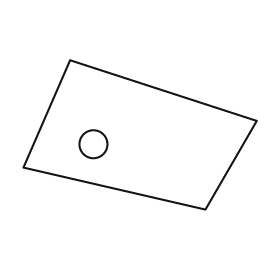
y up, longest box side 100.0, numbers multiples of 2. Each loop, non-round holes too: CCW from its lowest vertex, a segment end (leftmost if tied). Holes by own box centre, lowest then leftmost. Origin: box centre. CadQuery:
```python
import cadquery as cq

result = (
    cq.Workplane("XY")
    .moveTo(28.0, -32.0)
    .lineTo(50.0, 6.0)
    .lineTo(-30.0, 32.0)
    .lineTo(-50.0, -14.0)
    .close()
    .moveTo(-20.0, -4.0)
    .circle(6.0)
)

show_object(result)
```